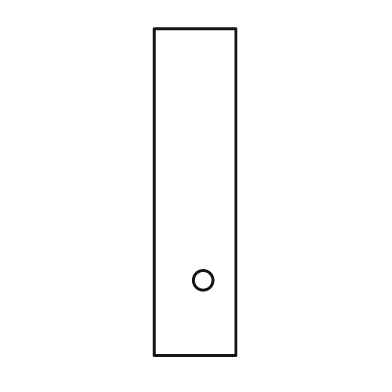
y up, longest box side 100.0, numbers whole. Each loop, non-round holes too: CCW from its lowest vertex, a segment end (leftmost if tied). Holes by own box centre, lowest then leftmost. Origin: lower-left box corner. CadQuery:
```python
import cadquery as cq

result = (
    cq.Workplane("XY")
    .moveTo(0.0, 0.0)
    .lineTo(25.0, 0.0)
    .lineTo(25.0, 100.0)
    .lineTo(0.0, 100.0)
    .close()
    .moveTo(15.0, 23.0)
    .circle(3.0)
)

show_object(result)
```